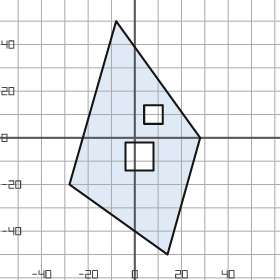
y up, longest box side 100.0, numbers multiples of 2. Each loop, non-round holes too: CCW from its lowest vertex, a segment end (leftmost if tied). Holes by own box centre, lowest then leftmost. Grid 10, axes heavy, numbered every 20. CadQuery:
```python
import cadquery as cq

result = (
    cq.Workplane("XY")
    .moveTo(14.0, -50.0)
    .lineTo(28.0, 0.0)
    .lineTo(-8.0, 50.0)
    .lineTo(-28.0, -20.0)
    .close()
    .moveTo(-4.0, -14.0)
    .lineTo(8.0, -14.0)
    .lineTo(8.0, -2.0)
    .lineTo(-4.0, -2.0)
    .close()
    .moveTo(4.0, 6.0)
    .lineTo(12.0, 6.0)
    .lineTo(12.0, 14.0)
    .lineTo(4.0, 14.0)
    .close()
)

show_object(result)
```